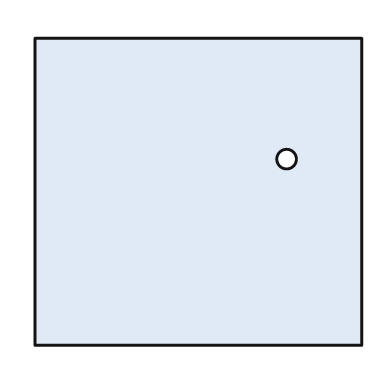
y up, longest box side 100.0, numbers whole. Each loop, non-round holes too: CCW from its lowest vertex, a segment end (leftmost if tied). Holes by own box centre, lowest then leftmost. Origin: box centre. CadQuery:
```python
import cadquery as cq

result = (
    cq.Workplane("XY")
    .moveTo(-50.0, -47.0)
    .lineTo(50.0, -47.0)
    .lineTo(50.0, 47.0)
    .lineTo(-50.0, 47.0)
    .close()
    .moveTo(27.0, 10.0)
    .circle(3.0)
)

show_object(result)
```